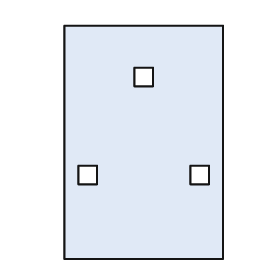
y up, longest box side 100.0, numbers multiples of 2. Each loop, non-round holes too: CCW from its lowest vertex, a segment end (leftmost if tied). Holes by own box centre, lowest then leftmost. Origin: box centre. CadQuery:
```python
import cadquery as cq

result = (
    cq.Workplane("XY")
    .moveTo(-34.0, -50.0)
    .lineTo(34.0, -50.0)
    .lineTo(34.0, 50.0)
    .lineTo(-34.0, 50.0)
    .close()
    .moveTo(-28.0, -18.0)
    .lineTo(-20.0, -18.0)
    .lineTo(-20.0, -10.0)
    .lineTo(-28.0, -10.0)
    .close()
    .moveTo(20.0, -18.0)
    .lineTo(28.0, -18.0)
    .lineTo(28.0, -10.0)
    .lineTo(20.0, -10.0)
    .close()
    .moveTo(-4.0, 24.0)
    .lineTo(4.0, 24.0)
    .lineTo(4.0, 32.0)
    .lineTo(-4.0, 32.0)
    .close()
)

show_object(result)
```